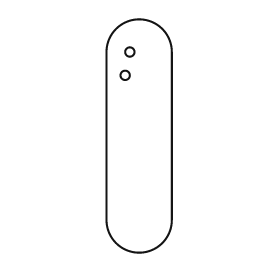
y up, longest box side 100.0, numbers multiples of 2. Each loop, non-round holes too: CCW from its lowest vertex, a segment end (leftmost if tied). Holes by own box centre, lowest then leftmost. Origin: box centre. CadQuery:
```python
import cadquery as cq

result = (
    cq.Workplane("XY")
    .moveTo(-14.0, -36.0)
    .threePointArc((0.0, -50.0), (14.0, -36.0))
    .lineTo(14.0, 36.0)
    .threePointArc((0.0, 50.0), (-14.0, 36.0))
    .close()
    .moveTo(-6.0, 26.0)
    .circle(2.0)
    .moveTo(-4.0, 36.0)
    .circle(2.0)
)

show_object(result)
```